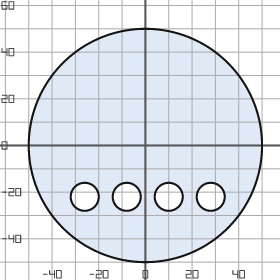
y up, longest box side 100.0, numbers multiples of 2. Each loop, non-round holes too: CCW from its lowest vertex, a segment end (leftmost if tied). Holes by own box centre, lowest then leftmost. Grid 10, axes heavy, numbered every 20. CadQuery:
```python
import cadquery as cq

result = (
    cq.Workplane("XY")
    .moveTo(0.0, 0.0)
    .circle(50.0)
    .moveTo(-26.0, -22.0)
    .circle(6.0)
    .moveTo(-8.0, -22.0)
    .circle(6.0)
    .moveTo(10.0, -22.0)
    .circle(6.0)
    .moveTo(28.0, -22.0)
    .circle(6.0)
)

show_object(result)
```